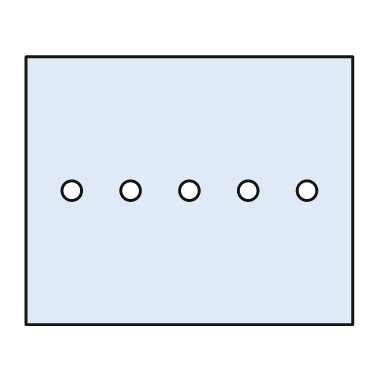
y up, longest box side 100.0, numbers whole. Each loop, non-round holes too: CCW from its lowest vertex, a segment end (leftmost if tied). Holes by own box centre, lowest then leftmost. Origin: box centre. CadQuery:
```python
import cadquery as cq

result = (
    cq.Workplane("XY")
    .moveTo(-50.0, -41.0)
    .lineTo(50.0, -41.0)
    .lineTo(50.0, 41.0)
    .lineTo(-50.0, 41.0)
    .close()
    .moveTo(-36.0, 0.0)
    .circle(3.0)
    .moveTo(-18.0, 0.0)
    .circle(3.0)
    .moveTo(0.0, 0.0)
    .circle(3.0)
    .moveTo(18.0, 0.0)
    .circle(3.0)
    .moveTo(36.0, 0.0)
    .circle(3.0)
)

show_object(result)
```